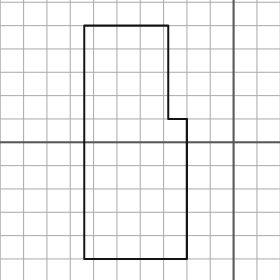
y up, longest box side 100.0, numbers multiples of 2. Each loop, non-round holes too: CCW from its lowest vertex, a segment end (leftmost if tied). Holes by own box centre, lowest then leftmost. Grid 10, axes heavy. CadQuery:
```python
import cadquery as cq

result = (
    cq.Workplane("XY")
    .moveTo(-64.0, -50.0)
    .lineTo(-20.0, -50.0)
    .lineTo(-20.0, 10.0)
    .lineTo(-28.0, 10.0)
    .lineTo(-28.0, 50.0)
    .lineTo(-64.0, 50.0)
    .close()
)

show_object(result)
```